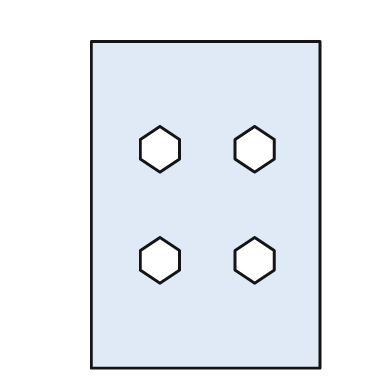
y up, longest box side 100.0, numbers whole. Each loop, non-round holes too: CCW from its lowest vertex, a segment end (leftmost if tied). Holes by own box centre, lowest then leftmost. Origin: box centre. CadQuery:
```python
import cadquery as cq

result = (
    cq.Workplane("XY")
    .moveTo(-35.0, -50.0)
    .lineTo(35.0, -50.0)
    .lineTo(35.0, 50.0)
    .lineTo(-35.0, 50.0)
    .close()
    .moveTo(-14.0, -24.0)
    .lineTo(-8.0, -20.0)
    .lineTo(-8.0, -14.0)
    .lineTo(-14.0, -10.0)
    .lineTo(-20.0, -14.0)
    .lineTo(-20.0, -20.0)
    .close()
    .moveTo(15.0, -24.0)
    .lineTo(21.0, -20.0)
    .lineTo(21.0, -14.0)
    .lineTo(15.0, -10.0)
    .lineTo(9.0, -14.0)
    .lineTo(9.0, -20.0)
    .close()
    .moveTo(-14.0, 10.0)
    .lineTo(-8.0, 14.0)
    .lineTo(-8.0, 20.0)
    .lineTo(-14.0, 24.0)
    .lineTo(-20.0, 20.0)
    .lineTo(-20.0, 14.0)
    .close()
    .moveTo(15.0, 10.0)
    .lineTo(21.0, 14.0)
    .lineTo(21.0, 20.0)
    .lineTo(15.0, 24.0)
    .lineTo(9.0, 20.0)
    .lineTo(9.0, 14.0)
    .close()
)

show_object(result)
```